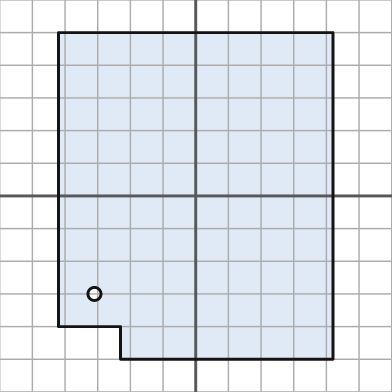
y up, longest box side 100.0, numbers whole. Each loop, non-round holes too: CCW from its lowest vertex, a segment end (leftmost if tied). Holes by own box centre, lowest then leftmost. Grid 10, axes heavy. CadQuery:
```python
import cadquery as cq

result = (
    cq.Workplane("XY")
    .moveTo(-23.0, -50.0)
    .lineTo(42.0, -50.0)
    .lineTo(42.0, 50.0)
    .lineTo(-42.0, 50.0)
    .lineTo(-42.0, -40.0)
    .lineTo(-23.0, -40.0)
    .close()
    .moveTo(-31.0, -30.0)
    .circle(2.0)
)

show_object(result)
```